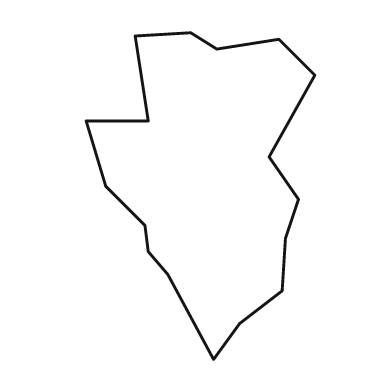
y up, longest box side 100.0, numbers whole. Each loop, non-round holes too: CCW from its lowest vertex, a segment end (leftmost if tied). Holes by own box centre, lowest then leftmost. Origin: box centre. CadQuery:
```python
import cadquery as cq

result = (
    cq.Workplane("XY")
    .moveTo(4.0, -50.0)
    .lineTo(12.0, -39.0)
    .lineTo(25.0, -29.0)
    .lineTo(26.0, -13.0)
    .lineTo(30.0, -1.0)
    .lineTo(21.0, 12.0)
    .lineTo(35.0, 37.0)
    .lineTo(24.0, 48.0)
    .lineTo(5.0, 45.0)
    .lineTo(-3.0, 50.0)
    .lineTo(-20.0, 49.0)
    .lineTo(-16.0, 23.0)
    .lineTo(-35.0, 23.0)
    .lineTo(-29.0, 3.0)
    .lineTo(-17.0, -9.0)
    .lineTo(-16.0, -17.0)
    .lineTo(-10.0, -24.0)
    .close()
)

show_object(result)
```